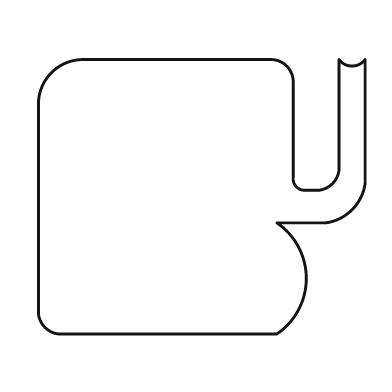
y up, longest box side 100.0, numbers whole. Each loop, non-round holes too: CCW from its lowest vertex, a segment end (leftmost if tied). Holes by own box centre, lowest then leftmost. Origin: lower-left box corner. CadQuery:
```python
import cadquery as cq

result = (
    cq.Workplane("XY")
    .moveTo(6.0, 0.0)
    .lineTo(73.0, 0.0)
    .threePointArc((82.0, 17.0), (73.0, 34.0))
    .lineTo(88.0, 34.0)
    .threePointArc((96.0, 38.0), (100.0, 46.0))
    .lineTo(100.0, 84.0)
    .threePointArc((96.0, 82.0), (92.0, 84.0))
    .lineTo(92.0, 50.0)
    .threePointArc((90.0, 46.0), (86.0, 44.0))
    .lineTo(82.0, 44.0)
    .threePointArc((79.0, 45.0), (78.0, 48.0))
    .lineTo(78.0, 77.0)
    .threePointArc((76.0, 82.0), (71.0, 84.0))
    .lineTo(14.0, 84.0)
    .threePointArc((4.0, 80.0), (0.0, 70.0))
    .lineTo(0.0, 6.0)
    .threePointArc((2.0, 2.0), (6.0, 0.0))
    .close()
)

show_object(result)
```